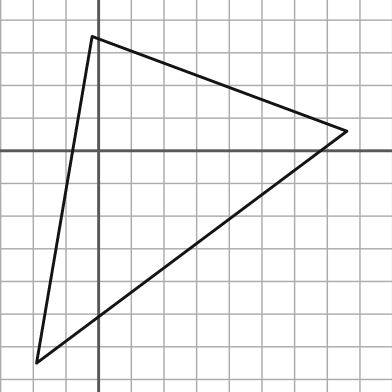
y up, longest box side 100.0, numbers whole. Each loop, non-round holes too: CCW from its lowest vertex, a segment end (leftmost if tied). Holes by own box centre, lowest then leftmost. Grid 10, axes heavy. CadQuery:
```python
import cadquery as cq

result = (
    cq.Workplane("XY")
    .moveTo(-19.0, -65.0)
    .lineTo(76.0, 6.0)
    .lineTo(-2.0, 35.0)
    .close()
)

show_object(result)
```